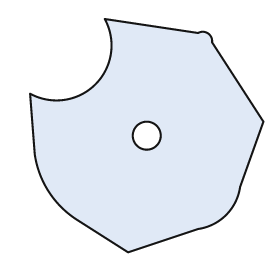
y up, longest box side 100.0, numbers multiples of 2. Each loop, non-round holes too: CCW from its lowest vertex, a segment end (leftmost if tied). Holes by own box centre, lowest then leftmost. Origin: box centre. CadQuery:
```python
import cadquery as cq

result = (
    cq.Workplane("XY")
    .moveTo(-8.0, -50.0)
    .lineTo(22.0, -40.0)
    .threePointArc((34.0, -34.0), (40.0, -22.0))
    .lineTo(50.0, 6.0)
    .lineTo(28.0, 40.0)
    .threePointArc((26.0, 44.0), (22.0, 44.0))
    .lineTo(-18.0, 50.0)
    .threePointArc((-22.0, 22.0), (-50.0, 18.0))
    .lineTo(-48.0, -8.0)
    .threePointArc((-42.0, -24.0), (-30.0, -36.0))
    .close()
    .moveTo(0.0, 0.0)
    .circle(6.0)
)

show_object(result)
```